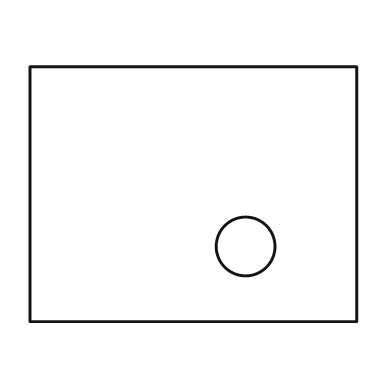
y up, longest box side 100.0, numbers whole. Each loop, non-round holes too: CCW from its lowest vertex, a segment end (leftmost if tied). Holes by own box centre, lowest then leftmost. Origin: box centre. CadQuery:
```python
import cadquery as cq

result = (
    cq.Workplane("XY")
    .moveTo(-50.0, -39.0)
    .lineTo(50.0, -39.0)
    .lineTo(50.0, 39.0)
    .lineTo(-50.0, 39.0)
    .close()
    .moveTo(16.0, -16.0)
    .circle(9.0)
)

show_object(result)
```